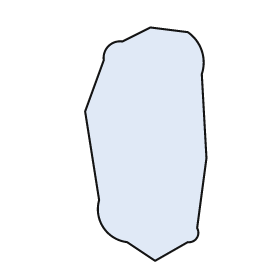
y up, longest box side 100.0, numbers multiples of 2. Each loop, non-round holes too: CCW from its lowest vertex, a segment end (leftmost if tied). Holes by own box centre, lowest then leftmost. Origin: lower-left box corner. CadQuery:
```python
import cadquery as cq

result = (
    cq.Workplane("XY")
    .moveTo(30.0, 0.0)
    .lineTo(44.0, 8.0)
    .threePointArc((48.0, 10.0), (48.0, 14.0))
    .lineTo(52.0, 44.0)
    .lineTo(50.0, 80.0)
    .threePointArc((50.0, 90.0), (44.0, 98.0))
    .lineTo(28.0, 100.0)
    .lineTo(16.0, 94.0)
    .threePointArc((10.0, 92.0), (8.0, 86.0))
    .lineTo(0.0, 64.0)
    .lineTo(6.0, 26.0)
    .threePointArc((8.0, 14.0), (18.0, 8.0))
    .close()
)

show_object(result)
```